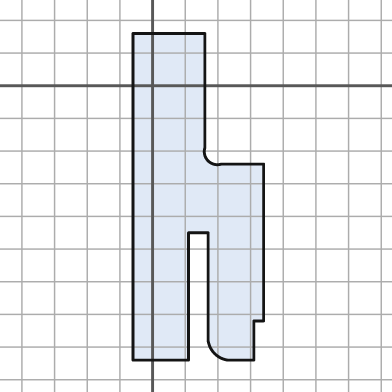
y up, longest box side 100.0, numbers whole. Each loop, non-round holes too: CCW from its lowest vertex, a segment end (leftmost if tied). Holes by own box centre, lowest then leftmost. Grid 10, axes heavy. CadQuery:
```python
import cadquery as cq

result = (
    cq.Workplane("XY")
    .moveTo(-6.0, -84.0)
    .lineTo(11.0, -84.0)
    .lineTo(11.0, -45.0)
    .lineTo(17.0, -45.0)
    .lineTo(17.0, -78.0)
    .threePointArc((19.0, -82.0), (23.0, -84.0))
    .lineTo(31.0, -84.0)
    .lineTo(31.0, -72.0)
    .lineTo(34.0, -72.0)
    .lineTo(34.0, -24.0)
    .lineTo(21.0, -24.0)
    .threePointArc((17.0, -23.0), (16.0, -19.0))
    .lineTo(16.0, 16.0)
    .lineTo(-6.0, 16.0)
    .close()
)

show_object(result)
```